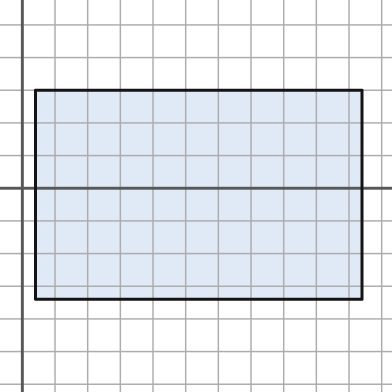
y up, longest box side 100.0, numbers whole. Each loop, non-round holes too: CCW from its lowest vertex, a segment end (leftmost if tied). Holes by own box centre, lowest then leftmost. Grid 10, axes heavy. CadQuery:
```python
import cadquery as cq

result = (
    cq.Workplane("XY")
    .moveTo(4.0, -34.0)
    .lineTo(104.0, -34.0)
    .lineTo(104.0, 30.0)
    .lineTo(4.0, 30.0)
    .close()
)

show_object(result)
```